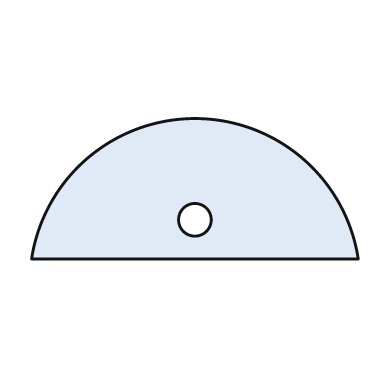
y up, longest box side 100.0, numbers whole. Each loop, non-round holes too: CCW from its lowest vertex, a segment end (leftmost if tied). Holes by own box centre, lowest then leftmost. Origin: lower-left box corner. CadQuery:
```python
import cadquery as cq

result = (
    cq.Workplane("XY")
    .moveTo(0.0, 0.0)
    .lineTo(100.0, 0.0)
    .threePointArc((50.0, 43.0), (0.0, 0.0))
    .close()
    .moveTo(50.0, 12.0)
    .circle(5.0)
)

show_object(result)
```